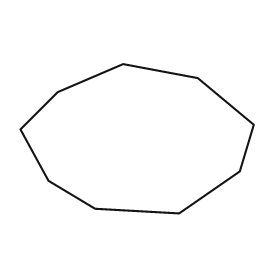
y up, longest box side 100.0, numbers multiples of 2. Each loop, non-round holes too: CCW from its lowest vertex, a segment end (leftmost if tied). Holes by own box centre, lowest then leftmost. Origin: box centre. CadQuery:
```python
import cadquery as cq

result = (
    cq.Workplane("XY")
    .moveTo(18.0, -32.0)
    .lineTo(44.0, -14.0)
    .lineTo(50.0, 6.0)
    .lineTo(26.0, 26.0)
    .lineTo(-6.0, 32.0)
    .lineTo(-34.0, 20.0)
    .lineTo(-50.0, 4.0)
    .lineTo(-38.0, -18.0)
    .lineTo(-18.0, -30.0)
    .close()
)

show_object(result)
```